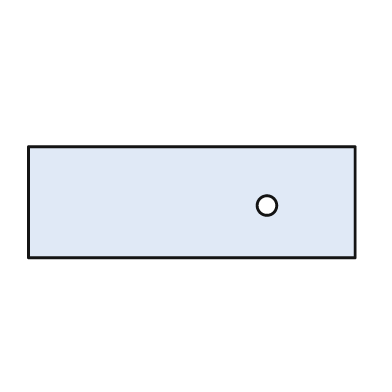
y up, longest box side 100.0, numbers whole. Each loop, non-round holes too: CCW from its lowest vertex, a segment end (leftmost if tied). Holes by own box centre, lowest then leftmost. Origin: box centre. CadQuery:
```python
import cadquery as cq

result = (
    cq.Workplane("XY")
    .moveTo(-50.0, -17.0)
    .lineTo(50.0, -17.0)
    .lineTo(50.0, 17.0)
    .lineTo(-50.0, 17.0)
    .close()
    .moveTo(23.0, -1.0)
    .circle(3.0)
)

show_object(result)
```